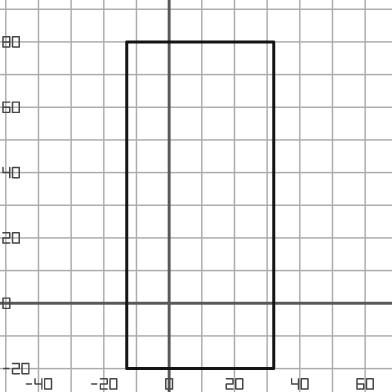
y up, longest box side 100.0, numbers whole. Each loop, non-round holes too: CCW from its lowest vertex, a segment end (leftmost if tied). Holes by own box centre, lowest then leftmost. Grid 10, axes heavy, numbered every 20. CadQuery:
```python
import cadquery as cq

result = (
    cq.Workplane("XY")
    .moveTo(-13.0, -20.0)
    .lineTo(32.0, -20.0)
    .lineTo(32.0, 80.0)
    .lineTo(-13.0, 80.0)
    .close()
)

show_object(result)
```